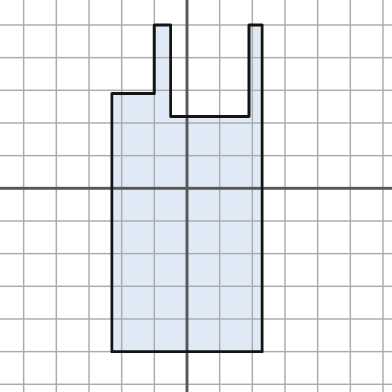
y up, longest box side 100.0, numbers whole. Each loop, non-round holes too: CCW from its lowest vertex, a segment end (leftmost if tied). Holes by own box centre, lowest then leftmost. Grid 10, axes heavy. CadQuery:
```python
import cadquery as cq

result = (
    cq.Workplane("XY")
    .moveTo(-23.0, -50.0)
    .lineTo(23.0, -50.0)
    .lineTo(23.0, 50.0)
    .lineTo(19.0, 50.0)
    .lineTo(19.0, 22.0)
    .lineTo(-5.0, 22.0)
    .lineTo(-5.0, 50.0)
    .lineTo(-10.0, 50.0)
    .lineTo(-10.0, 29.0)
    .lineTo(-23.0, 29.0)
    .close()
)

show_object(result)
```